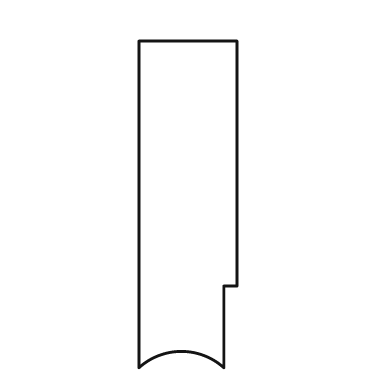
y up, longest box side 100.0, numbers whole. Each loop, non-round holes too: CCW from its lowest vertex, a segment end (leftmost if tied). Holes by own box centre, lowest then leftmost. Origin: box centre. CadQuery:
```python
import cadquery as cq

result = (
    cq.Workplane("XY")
    .moveTo(-15.0, -50.0)
    .threePointArc((-2.0, -45.0), (11.0, -50.0))
    .lineTo(11.0, -25.0)
    .lineTo(15.0, -25.0)
    .lineTo(15.0, 50.0)
    .lineTo(-15.0, 50.0)
    .close()
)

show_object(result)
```